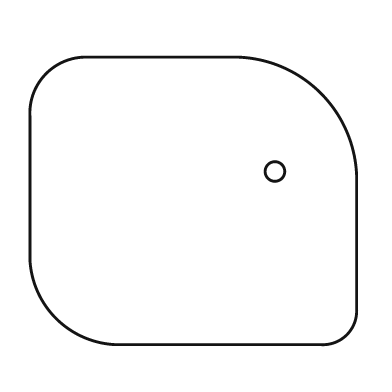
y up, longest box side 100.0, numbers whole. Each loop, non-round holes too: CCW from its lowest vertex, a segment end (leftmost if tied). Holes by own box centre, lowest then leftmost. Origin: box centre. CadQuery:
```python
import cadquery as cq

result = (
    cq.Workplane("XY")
    .moveTo(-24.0, -44.0)
    .lineTo(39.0, -44.0)
    .threePointArc((47.0, -41.0), (50.0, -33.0))
    .lineTo(50.0, 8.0)
    .threePointArc((39.0, 33.0), (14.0, 44.0))
    .lineTo(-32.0, 44.0)
    .threePointArc((-45.0, 39.0), (-50.0, 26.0))
    .lineTo(-50.0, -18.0)
    .threePointArc((-42.0, -36.0), (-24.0, -44.0))
    .close()
    .moveTo(25.0, 9.0)
    .circle(3.0)
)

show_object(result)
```